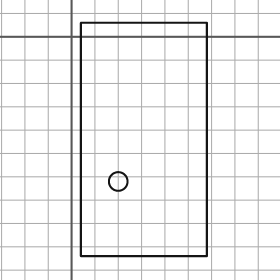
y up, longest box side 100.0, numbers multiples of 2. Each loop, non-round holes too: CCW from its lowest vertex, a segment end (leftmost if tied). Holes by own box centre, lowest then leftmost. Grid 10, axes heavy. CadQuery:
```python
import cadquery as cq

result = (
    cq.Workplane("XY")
    .moveTo(4.0, -94.0)
    .lineTo(58.0, -94.0)
    .lineTo(58.0, 6.0)
    .lineTo(4.0, 6.0)
    .close()
    .moveTo(20.0, -62.0)
    .circle(4.0)
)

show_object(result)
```